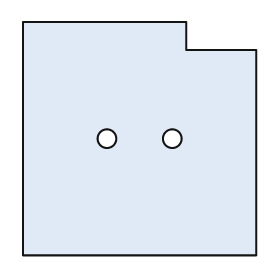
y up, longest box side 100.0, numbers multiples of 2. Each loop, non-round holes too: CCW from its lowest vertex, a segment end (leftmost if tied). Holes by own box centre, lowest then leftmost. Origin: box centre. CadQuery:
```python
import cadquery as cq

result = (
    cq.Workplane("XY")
    .moveTo(-50.0, -50.0)
    .lineTo(50.0, -50.0)
    .lineTo(50.0, 38.0)
    .lineTo(20.0, 38.0)
    .lineTo(20.0, 50.0)
    .lineTo(-50.0, 50.0)
    .close()
    .moveTo(-14.0, 0.0)
    .circle(4.0)
    .moveTo(14.0, 0.0)
    .circle(4.0)
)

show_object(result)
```